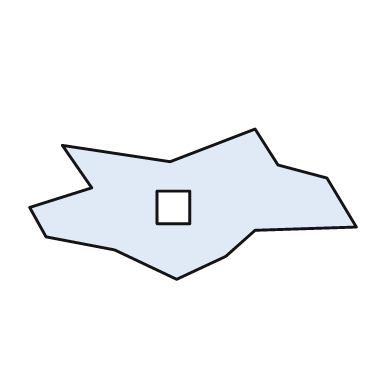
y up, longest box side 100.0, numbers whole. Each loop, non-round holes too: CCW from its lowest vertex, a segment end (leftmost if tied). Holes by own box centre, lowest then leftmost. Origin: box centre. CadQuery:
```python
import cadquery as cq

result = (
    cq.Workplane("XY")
    .moveTo(-5.0, -23.0)
    .lineTo(10.0, -16.0)
    .lineTo(19.0, -8.0)
    .lineTo(50.0, -7.0)
    .lineTo(41.0, 8.0)
    .lineTo(26.0, 12.0)
    .lineTo(19.0, 23.0)
    .lineTo(-7.0, 13.0)
    .lineTo(-40.0, 18.0)
    .lineTo(-31.0, 5.0)
    .lineTo(-50.0, -1.0)
    .lineTo(-45.0, -10.0)
    .lineTo(-24.0, -14.0)
    .close()
    .moveTo(-11.0, -6.0)
    .lineTo(-1.0, -6.0)
    .lineTo(-1.0, 4.0)
    .lineTo(-11.0, 4.0)
    .close()
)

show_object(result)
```